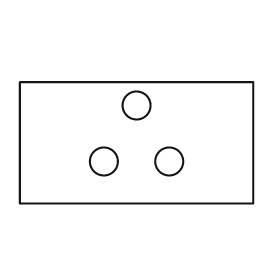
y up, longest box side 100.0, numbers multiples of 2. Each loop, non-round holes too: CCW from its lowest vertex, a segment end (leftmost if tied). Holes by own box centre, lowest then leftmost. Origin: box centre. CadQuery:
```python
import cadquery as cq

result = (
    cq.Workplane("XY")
    .moveTo(-50.0, -26.0)
    .lineTo(50.0, -26.0)
    .lineTo(50.0, 26.0)
    .lineTo(-50.0, 26.0)
    .close()
    .moveTo(-14.0, -8.0)
    .circle(6.0)
    .moveTo(14.0, -8.0)
    .circle(6.0)
    .moveTo(0.0, 16.0)
    .circle(6.0)
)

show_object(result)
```